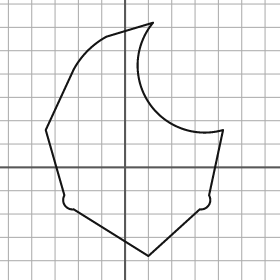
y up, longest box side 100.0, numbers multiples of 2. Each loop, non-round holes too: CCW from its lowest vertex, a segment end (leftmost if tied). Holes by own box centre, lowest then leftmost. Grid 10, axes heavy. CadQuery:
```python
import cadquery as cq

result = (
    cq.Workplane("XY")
    .moveTo(10.0, -38.0)
    .lineTo(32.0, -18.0)
    .threePointArc((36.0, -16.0), (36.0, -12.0))
    .lineTo(42.0, 16.0)
    .threePointArc((10.0, 28.0), (12.0, 62.0))
    .lineTo(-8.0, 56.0)
    .threePointArc((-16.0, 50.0), (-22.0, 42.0))
    .lineTo(-34.0, 16.0)
    .lineTo(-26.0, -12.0)
    .threePointArc((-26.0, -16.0), (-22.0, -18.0))
    .close()
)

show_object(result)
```